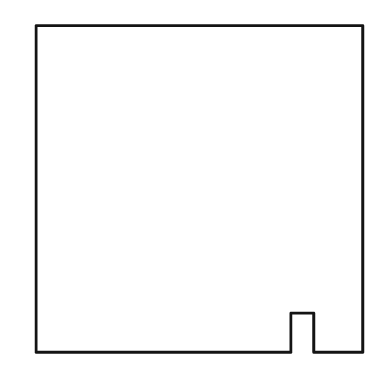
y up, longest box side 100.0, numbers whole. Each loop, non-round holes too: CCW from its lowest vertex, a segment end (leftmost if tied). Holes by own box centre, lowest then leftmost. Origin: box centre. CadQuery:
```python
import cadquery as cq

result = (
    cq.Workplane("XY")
    .moveTo(-50.0, -50.0)
    .lineTo(28.0, -50.0)
    .lineTo(28.0, -38.0)
    .lineTo(35.0, -38.0)
    .lineTo(35.0, -50.0)
    .lineTo(50.0, -50.0)
    .lineTo(50.0, 50.0)
    .lineTo(-50.0, 50.0)
    .close()
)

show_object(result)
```